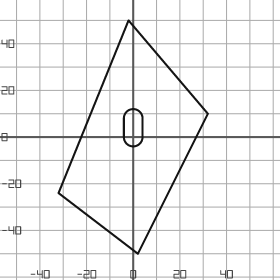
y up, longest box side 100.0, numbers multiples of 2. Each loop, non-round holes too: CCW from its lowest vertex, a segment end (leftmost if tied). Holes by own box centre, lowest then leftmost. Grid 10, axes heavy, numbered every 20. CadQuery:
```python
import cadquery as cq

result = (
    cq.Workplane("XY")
    .moveTo(2.0, -50.0)
    .lineTo(32.0, 10.0)
    .lineTo(-2.0, 50.0)
    .lineTo(-32.0, -24.0)
    .close()
    .moveTo(-4.0, 0.0)
    .threePointArc((0.0, -4.0), (4.0, 0.0))
    .lineTo(4.0, 8.0)
    .threePointArc((0.0, 12.0), (-4.0, 8.0))
    .close()
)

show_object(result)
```